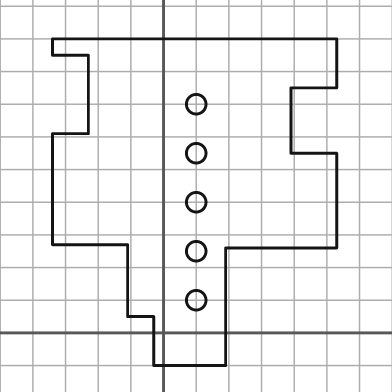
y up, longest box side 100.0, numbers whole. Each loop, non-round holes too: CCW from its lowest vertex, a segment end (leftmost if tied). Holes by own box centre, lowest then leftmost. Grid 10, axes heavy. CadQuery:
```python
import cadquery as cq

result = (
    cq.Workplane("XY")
    .moveTo(-3.0, -10.0)
    .lineTo(19.0, -10.0)
    .lineTo(19.0, 26.0)
    .lineTo(53.0, 26.0)
    .lineTo(53.0, 55.0)
    .lineTo(39.0, 55.0)
    .lineTo(39.0, 75.0)
    .lineTo(53.0, 75.0)
    .lineTo(53.0, 90.0)
    .lineTo(-34.0, 90.0)
    .lineTo(-34.0, 85.0)
    .lineTo(-23.0, 85.0)
    .lineTo(-23.0, 61.0)
    .lineTo(-34.0, 61.0)
    .lineTo(-34.0, 27.0)
    .lineTo(-11.0, 27.0)
    .lineTo(-11.0, 5.0)
    .lineTo(-3.0, 5.0)
    .close()
    .moveTo(10.0, 10.0)
    .circle(3.0)
    .moveTo(10.0, 25.0)
    .circle(3.0)
    .moveTo(10.0, 40.0)
    .circle(3.0)
    .moveTo(10.0, 55.0)
    .circle(3.0)
    .moveTo(10.0, 70.0)
    .circle(3.0)
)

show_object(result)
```